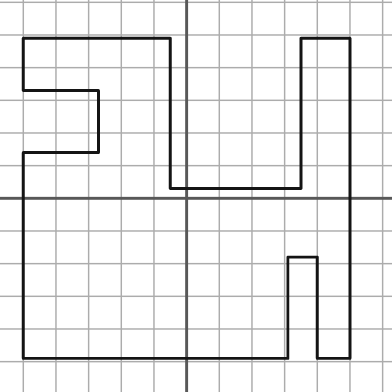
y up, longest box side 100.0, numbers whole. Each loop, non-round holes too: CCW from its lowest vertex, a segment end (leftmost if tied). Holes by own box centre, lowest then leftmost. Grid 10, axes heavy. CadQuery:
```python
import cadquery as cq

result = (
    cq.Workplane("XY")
    .moveTo(-50.0, -49.0)
    .lineTo(31.0, -49.0)
    .lineTo(31.0, -18.0)
    .lineTo(40.0, -18.0)
    .lineTo(40.0, -49.0)
    .lineTo(50.0, -49.0)
    .lineTo(50.0, 49.0)
    .lineTo(35.0, 49.0)
    .lineTo(35.0, 3.0)
    .lineTo(-5.0, 3.0)
    .lineTo(-5.0, 49.0)
    .lineTo(-50.0, 49.0)
    .lineTo(-50.0, 33.0)
    .lineTo(-27.0, 33.0)
    .lineTo(-27.0, 14.0)
    .lineTo(-50.0, 14.0)
    .close()
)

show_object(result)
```